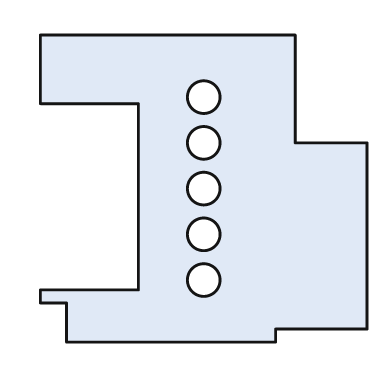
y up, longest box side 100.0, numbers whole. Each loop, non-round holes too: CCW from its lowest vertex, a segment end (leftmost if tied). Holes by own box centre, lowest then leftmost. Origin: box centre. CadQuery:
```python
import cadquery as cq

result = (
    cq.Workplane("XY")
    .moveTo(-42.0, -47.0)
    .lineTo(22.0, -47.0)
    .lineTo(22.0, -43.0)
    .lineTo(50.0, -43.0)
    .lineTo(50.0, 14.0)
    .lineTo(28.0, 14.0)
    .lineTo(28.0, 47.0)
    .lineTo(-50.0, 47.0)
    .lineTo(-50.0, 26.0)
    .lineTo(-20.0, 26.0)
    .lineTo(-20.0, -31.0)
    .lineTo(-50.0, -31.0)
    .lineTo(-50.0, -35.0)
    .lineTo(-42.0, -35.0)
    .close()
    .moveTo(0.0, -28.0)
    .circle(5.0)
    .moveTo(0.0, -14.0)
    .circle(5.0)
    .moveTo(0.0, 0.0)
    .circle(5.0)
    .moveTo(0.0, 14.0)
    .circle(5.0)
    .moveTo(0.0, 28.0)
    .circle(5.0)
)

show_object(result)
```